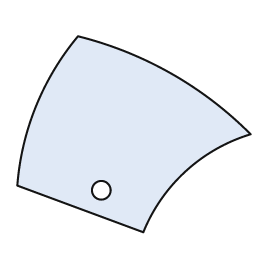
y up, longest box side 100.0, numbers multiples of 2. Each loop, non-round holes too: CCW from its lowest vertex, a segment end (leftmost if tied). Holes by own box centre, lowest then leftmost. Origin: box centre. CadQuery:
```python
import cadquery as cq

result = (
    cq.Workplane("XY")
    .moveTo(4.0, -42.0)
    .threePointArc((22.0, -16.0), (50.0, 0.0))
    .threePointArc((16.0, 26.0), (-24.0, 42.0))
    .threePointArc((-42.0, 12.0), (-50.0, -22.0))
    .close()
    .moveTo(-14.0, -24.0)
    .circle(4.0)
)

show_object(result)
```